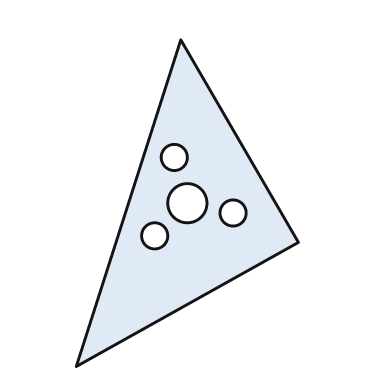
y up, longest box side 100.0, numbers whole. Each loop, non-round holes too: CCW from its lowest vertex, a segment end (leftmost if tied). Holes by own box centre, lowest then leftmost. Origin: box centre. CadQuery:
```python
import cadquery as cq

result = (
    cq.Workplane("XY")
    .moveTo(-34.0, -50.0)
    .lineTo(34.0, -12.0)
    .lineTo(-2.0, 50.0)
    .close()
    .moveTo(-10.0, -10.0)
    .circle(4.0)
    .moveTo(14.0, -3.0)
    .circle(4.0)
    .moveTo(0.0, 0.0)
    .circle(6.0)
    .moveTo(-4.0, 14.0)
    .circle(4.0)
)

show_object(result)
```